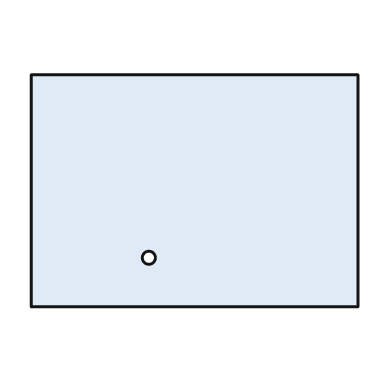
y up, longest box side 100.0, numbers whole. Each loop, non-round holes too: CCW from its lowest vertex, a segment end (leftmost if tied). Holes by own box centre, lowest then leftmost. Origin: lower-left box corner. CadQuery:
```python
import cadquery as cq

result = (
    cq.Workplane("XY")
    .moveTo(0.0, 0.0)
    .lineTo(100.0, 0.0)
    .lineTo(100.0, 71.0)
    .lineTo(0.0, 71.0)
    .close()
    .moveTo(36.0, 15.0)
    .circle(2.0)
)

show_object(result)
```